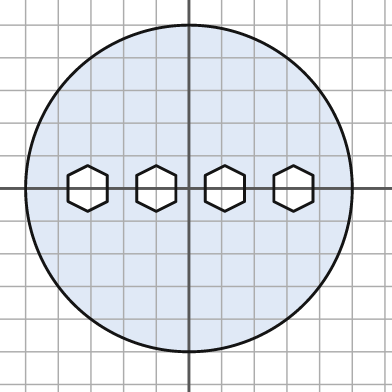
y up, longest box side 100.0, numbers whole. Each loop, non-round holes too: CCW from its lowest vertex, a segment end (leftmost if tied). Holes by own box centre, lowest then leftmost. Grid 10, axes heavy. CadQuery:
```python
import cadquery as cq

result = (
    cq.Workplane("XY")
    .moveTo(0.0, 0.0)
    .circle(50.0)
    .moveTo(-31.0, -7.0)
    .lineTo(-25.0, -4.0)
    .lineTo(-25.0, 4.0)
    .lineTo(-31.0, 7.0)
    .lineTo(-37.0, 4.0)
    .lineTo(-37.0, -4.0)
    .close()
    .moveTo(-10.0, -7.0)
    .lineTo(-4.0, -4.0)
    .lineTo(-4.0, 4.0)
    .lineTo(-10.0, 7.0)
    .lineTo(-16.0, 4.0)
    .lineTo(-16.0, -4.0)
    .close()
    .moveTo(11.0, -7.0)
    .lineTo(17.0, -4.0)
    .lineTo(17.0, 4.0)
    .lineTo(11.0, 7.0)
    .lineTo(5.0, 4.0)
    .lineTo(5.0, -4.0)
    .close()
    .moveTo(32.0, -7.0)
    .lineTo(38.0, -4.0)
    .lineTo(38.0, 4.0)
    .lineTo(32.0, 7.0)
    .lineTo(26.0, 4.0)
    .lineTo(26.0, -4.0)
    .close()
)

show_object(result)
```